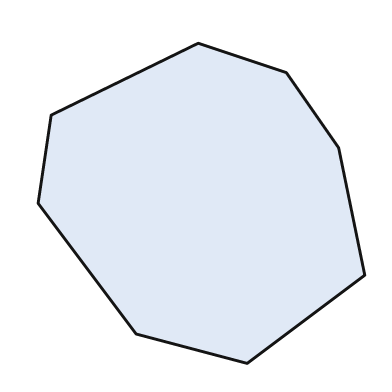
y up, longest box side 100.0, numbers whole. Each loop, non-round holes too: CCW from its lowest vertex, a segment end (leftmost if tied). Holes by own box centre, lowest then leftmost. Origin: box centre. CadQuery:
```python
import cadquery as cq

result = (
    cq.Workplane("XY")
    .moveTo(14.0, -49.0)
    .lineTo(50.0, -22.0)
    .lineTo(42.0, 17.0)
    .lineTo(26.0, 40.0)
    .lineTo(-1.0, 49.0)
    .lineTo(-46.0, 27.0)
    .lineTo(-50.0, 0.0)
    .lineTo(-20.0, -40.0)
    .close()
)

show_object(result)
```